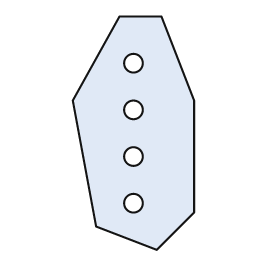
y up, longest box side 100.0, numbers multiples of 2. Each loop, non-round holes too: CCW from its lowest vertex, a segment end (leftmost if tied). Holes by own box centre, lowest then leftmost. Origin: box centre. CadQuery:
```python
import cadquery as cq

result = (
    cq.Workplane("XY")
    .moveTo(10.0, -50.0)
    .lineTo(26.0, -34.0)
    .lineTo(26.0, 14.0)
    .lineTo(12.0, 50.0)
    .lineTo(-6.0, 50.0)
    .lineTo(-26.0, 14.0)
    .lineTo(-16.0, -40.0)
    .close()
    .moveTo(0.0, -30.0)
    .circle(4.0)
    .moveTo(0.0, -10.0)
    .circle(4.0)
    .moveTo(0.0, 10.0)
    .circle(4.0)
    .moveTo(0.0, 30.0)
    .circle(4.0)
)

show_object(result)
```